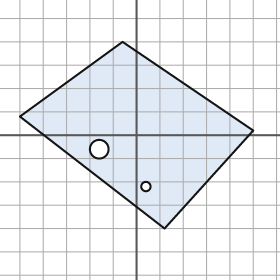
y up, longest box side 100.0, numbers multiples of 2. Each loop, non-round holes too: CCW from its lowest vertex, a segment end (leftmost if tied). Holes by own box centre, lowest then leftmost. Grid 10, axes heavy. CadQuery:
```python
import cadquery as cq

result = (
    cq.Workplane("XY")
    .moveTo(12.0, -40.0)
    .lineTo(50.0, 2.0)
    .lineTo(-6.0, 40.0)
    .lineTo(-50.0, 8.0)
    .close()
    .moveTo(4.0, -22.0)
    .circle(2.0)
    .moveTo(-16.0, -6.0)
    .circle(4.0)
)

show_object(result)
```